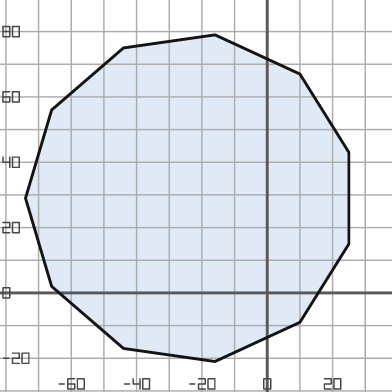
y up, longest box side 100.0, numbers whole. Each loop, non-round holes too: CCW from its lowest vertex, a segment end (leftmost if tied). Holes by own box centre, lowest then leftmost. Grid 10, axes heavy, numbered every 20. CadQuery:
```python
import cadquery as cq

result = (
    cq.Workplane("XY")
    .moveTo(-16.0, -21.0)
    .lineTo(10.0, -9.0)
    .lineTo(25.0, 15.0)
    .lineTo(25.0, 43.0)
    .lineTo(10.0, 67.0)
    .lineTo(-16.0, 79.0)
    .lineTo(-44.0, 75.0)
    .lineTo(-66.0, 56.0)
    .lineTo(-74.0, 29.0)
    .lineTo(-66.0, 2.0)
    .lineTo(-44.0, -17.0)
    .close()
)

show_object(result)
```